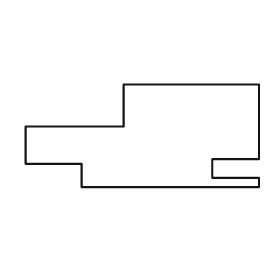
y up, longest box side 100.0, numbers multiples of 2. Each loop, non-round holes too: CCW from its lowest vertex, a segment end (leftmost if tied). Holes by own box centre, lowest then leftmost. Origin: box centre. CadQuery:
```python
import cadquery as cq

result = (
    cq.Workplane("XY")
    .moveTo(-26.0, -22.0)
    .lineTo(50.0, -22.0)
    .lineTo(50.0, -18.0)
    .lineTo(30.0, -18.0)
    .lineTo(30.0, -10.0)
    .lineTo(50.0, -10.0)
    .lineTo(50.0, 22.0)
    .lineTo(-8.0, 22.0)
    .lineTo(-8.0, 4.0)
    .lineTo(-50.0, 4.0)
    .lineTo(-50.0, -12.0)
    .lineTo(-26.0, -12.0)
    .close()
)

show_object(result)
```